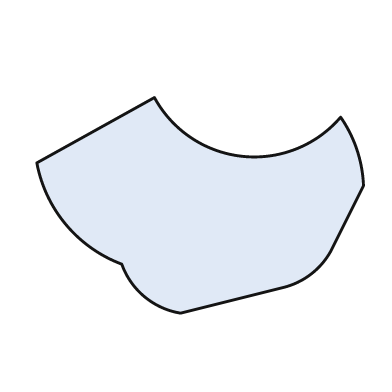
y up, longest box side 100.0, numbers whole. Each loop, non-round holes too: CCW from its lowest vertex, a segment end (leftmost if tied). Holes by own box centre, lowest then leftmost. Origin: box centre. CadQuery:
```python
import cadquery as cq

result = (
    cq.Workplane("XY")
    .moveTo(-6.0, -33.0)
    .lineTo(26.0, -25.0)
    .threePointArc((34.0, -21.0), (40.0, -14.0))
    .lineTo(50.0, 6.0)
    .threePointArc((48.0, 17.0), (43.0, 27.0))
    .threePointArc((13.0, 15.0), (-14.0, 33.0))
    .lineTo(-50.0, 13.0)
    .threePointArc((-41.0, -6.0), (-24.0, -18.0))
    .threePointArc((-17.0, -28.0), (-6.0, -33.0))
    .close()
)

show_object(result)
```